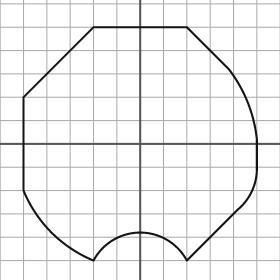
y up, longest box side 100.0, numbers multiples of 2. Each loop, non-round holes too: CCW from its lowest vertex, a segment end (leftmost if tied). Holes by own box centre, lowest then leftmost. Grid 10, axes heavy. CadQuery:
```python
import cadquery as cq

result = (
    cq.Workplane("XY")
    .moveTo(-20.0, -50.0)
    .threePointArc((0.0, -38.0), (20.0, -50.0))
    .lineTo(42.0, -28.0)
    .threePointArc((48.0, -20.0), (50.0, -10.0))
    .lineTo(50.0, 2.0)
    .threePointArc((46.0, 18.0), (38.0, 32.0))
    .lineTo(20.0, 50.0)
    .lineTo(-20.0, 50.0)
    .lineTo(-50.0, 20.0)
    .lineTo(-50.0, -20.0)
    .threePointArc((-38.0, -38.0), (-20.0, -50.0))
    .close()
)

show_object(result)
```